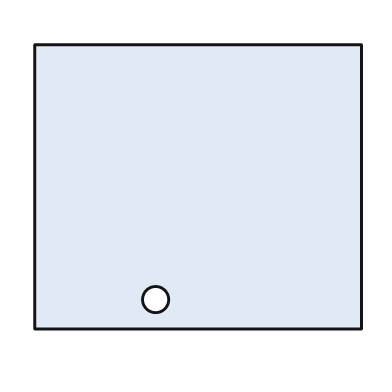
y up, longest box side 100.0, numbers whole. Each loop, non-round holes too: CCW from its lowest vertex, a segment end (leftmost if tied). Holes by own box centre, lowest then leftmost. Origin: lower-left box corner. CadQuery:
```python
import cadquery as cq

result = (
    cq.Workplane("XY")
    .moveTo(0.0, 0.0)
    .lineTo(100.0, 0.0)
    .lineTo(100.0, 87.0)
    .lineTo(0.0, 87.0)
    .close()
    .moveTo(37.0, 9.0)
    .circle(4.0)
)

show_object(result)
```